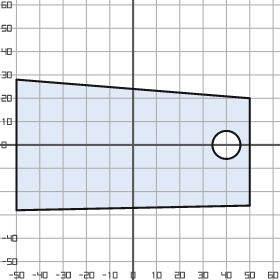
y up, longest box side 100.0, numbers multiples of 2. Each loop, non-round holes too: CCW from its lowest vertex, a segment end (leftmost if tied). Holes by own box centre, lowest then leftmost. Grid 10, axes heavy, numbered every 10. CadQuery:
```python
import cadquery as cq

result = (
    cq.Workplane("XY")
    .moveTo(-50.0, -28.0)
    .lineTo(50.0, -26.0)
    .lineTo(50.0, 20.0)
    .lineTo(-50.0, 28.0)
    .close()
    .moveTo(40.0, 0.0)
    .circle(6.0)
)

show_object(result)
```